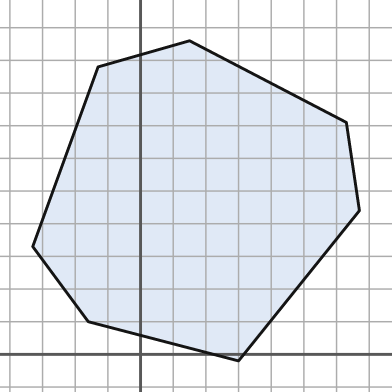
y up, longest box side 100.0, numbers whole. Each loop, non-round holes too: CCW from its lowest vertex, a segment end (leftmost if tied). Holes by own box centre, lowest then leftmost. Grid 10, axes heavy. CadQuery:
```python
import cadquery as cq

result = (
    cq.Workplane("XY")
    .moveTo(30.0, -2.0)
    .lineTo(67.0, 44.0)
    .lineTo(63.0, 71.0)
    .lineTo(15.0, 96.0)
    .lineTo(-13.0, 88.0)
    .lineTo(-33.0, 33.0)
    .lineTo(-16.0, 10.0)
    .close()
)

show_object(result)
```